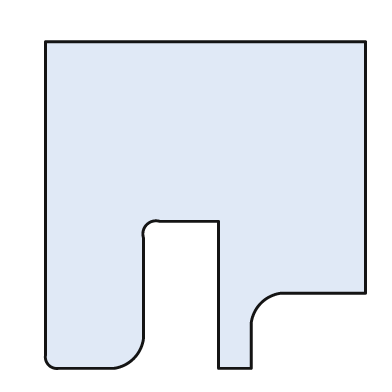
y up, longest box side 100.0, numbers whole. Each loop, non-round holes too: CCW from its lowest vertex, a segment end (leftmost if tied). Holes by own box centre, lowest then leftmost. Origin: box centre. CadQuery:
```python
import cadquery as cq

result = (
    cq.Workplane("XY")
    .moveTo(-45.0, -50.0)
    .lineTo(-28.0, -50.0)
    .threePointArc((-22.0, -47.0), (-19.0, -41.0))
    .lineTo(-19.0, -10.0)
    .threePointArc((-18.0, -6.0), (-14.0, -5.0))
    .lineTo(4.0, -5.0)
    .lineTo(4.0, -50.0)
    .lineTo(14.0, -50.0)
    .lineTo(14.0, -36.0)
    .threePointArc((17.0, -30.0), (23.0, -27.0))
    .lineTo(49.0, -27.0)
    .lineTo(49.0, 50.0)
    .lineTo(-49.0, 50.0)
    .lineTo(-49.0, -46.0)
    .threePointArc((-48.0, -49.0), (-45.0, -50.0))
    .close()
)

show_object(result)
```